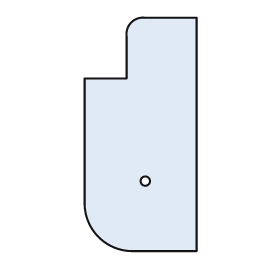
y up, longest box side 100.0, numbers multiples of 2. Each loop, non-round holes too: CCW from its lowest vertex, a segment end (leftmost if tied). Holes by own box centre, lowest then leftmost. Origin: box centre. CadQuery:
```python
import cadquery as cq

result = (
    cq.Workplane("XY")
    .moveTo(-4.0, -50.0)
    .lineTo(24.0, -50.0)
    .lineTo(24.0, 50.0)
    .lineTo(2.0, 50.0)
    .threePointArc((-4.0, 48.0), (-6.0, 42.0))
    .lineTo(-6.0, 24.0)
    .lineTo(-24.0, 24.0)
    .lineTo(-24.0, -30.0)
    .threePointArc((-18.0, -44.0), (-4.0, -50.0))
    .close()
    .moveTo(2.0, -20.0)
    .circle(2.0)
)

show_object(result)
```